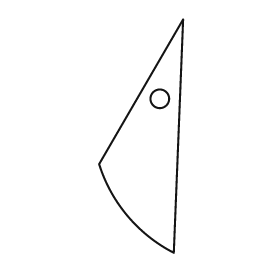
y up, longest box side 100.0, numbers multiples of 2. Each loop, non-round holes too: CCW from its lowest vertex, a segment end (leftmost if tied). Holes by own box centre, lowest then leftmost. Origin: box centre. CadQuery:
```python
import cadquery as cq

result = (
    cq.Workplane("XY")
    .moveTo(14.0, -50.0)
    .lineTo(18.0, 50.0)
    .lineTo(-18.0, -12.0)
    .threePointArc((-6.0, -34.0), (14.0, -50.0))
    .close()
    .moveTo(8.0, 16.0)
    .circle(4.0)
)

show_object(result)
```